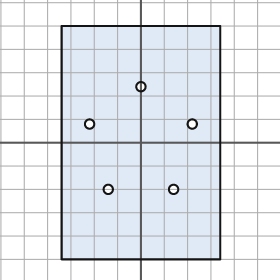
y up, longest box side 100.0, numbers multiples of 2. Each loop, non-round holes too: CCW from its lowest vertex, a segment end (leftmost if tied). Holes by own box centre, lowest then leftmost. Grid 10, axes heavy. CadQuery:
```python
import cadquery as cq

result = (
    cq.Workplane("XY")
    .moveTo(-34.0, -50.0)
    .lineTo(34.0, -50.0)
    .lineTo(34.0, 50.0)
    .lineTo(-34.0, 50.0)
    .close()
    .moveTo(-14.0, -20.0)
    .circle(2.0)
    .moveTo(14.0, -20.0)
    .circle(2.0)
    .moveTo(-22.0, 8.0)
    .circle(2.0)
    .moveTo(22.0, 8.0)
    .circle(2.0)
    .moveTo(0.0, 24.0)
    .circle(2.0)
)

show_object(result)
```